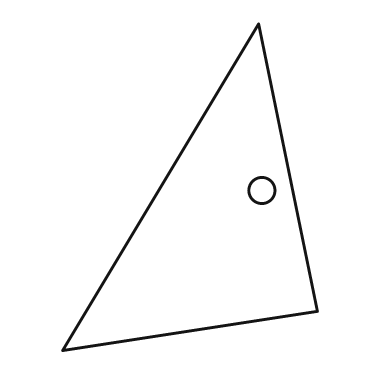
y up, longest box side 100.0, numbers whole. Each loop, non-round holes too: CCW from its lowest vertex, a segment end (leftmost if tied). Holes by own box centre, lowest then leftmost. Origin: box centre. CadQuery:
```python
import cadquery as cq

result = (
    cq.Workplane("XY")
    .moveTo(-39.0, -50.0)
    .lineTo(39.0, -38.0)
    .lineTo(21.0, 50.0)
    .close()
    .moveTo(22.0, -1.0)
    .circle(4.0)
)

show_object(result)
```